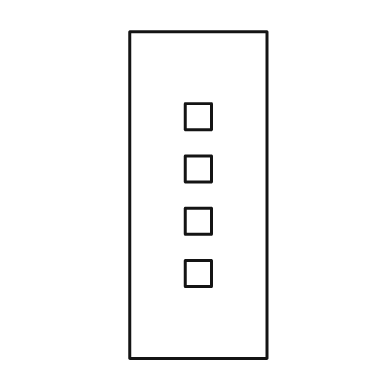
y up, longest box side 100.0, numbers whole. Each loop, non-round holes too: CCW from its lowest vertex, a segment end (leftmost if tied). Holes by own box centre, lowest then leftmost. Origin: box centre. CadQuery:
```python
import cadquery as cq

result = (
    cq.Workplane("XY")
    .moveTo(-21.0, -50.0)
    .lineTo(21.0, -50.0)
    .lineTo(21.0, 50.0)
    .lineTo(-21.0, 50.0)
    .close()
    .moveTo(-4.0, -28.0)
    .lineTo(4.0, -28.0)
    .lineTo(4.0, -20.0)
    .lineTo(-4.0, -20.0)
    .close()
    .moveTo(-4.0, -12.0)
    .lineTo(4.0, -12.0)
    .lineTo(4.0, -4.0)
    .lineTo(-4.0, -4.0)
    .close()
    .moveTo(-4.0, 4.0)
    .lineTo(4.0, 4.0)
    .lineTo(4.0, 12.0)
    .lineTo(-4.0, 12.0)
    .close()
    .moveTo(-4.0, 20.0)
    .lineTo(4.0, 20.0)
    .lineTo(4.0, 28.0)
    .lineTo(-4.0, 28.0)
    .close()
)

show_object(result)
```